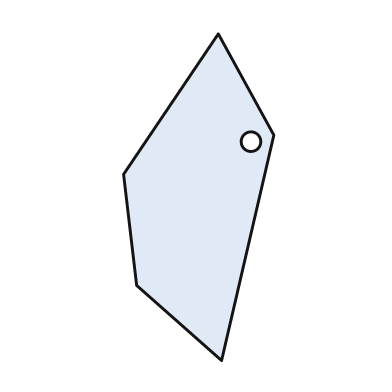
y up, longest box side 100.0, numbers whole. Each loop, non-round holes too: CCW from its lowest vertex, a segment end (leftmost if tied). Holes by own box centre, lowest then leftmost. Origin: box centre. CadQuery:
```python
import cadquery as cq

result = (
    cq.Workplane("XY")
    .moveTo(7.0, -50.0)
    .lineTo(23.0, 19.0)
    .lineTo(6.0, 50.0)
    .lineTo(-23.0, 7.0)
    .lineTo(-19.0, -27.0)
    .close()
    .moveTo(16.0, 17.0)
    .circle(3.0)
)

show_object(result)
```